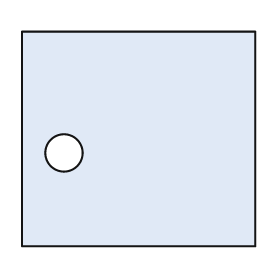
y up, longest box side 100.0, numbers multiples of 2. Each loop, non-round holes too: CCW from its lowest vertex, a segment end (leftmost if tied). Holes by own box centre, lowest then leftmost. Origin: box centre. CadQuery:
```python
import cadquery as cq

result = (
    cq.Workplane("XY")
    .moveTo(-50.0, -46.0)
    .lineTo(50.0, -46.0)
    .lineTo(50.0, 46.0)
    .lineTo(-50.0, 46.0)
    .close()
    .moveTo(-32.0, -6.0)
    .circle(8.0)
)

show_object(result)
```